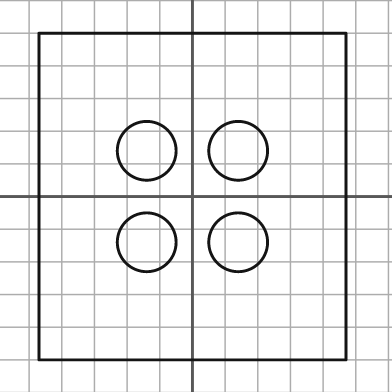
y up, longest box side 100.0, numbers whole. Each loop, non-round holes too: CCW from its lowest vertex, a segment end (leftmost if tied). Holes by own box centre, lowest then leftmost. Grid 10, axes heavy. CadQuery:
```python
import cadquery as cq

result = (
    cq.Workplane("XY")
    .moveTo(-47.0, -50.0)
    .lineTo(47.0, -50.0)
    .lineTo(47.0, 50.0)
    .lineTo(-47.0, 50.0)
    .close()
    .moveTo(-14.0, -14.0)
    .circle(9.0)
    .moveTo(14.0, -14.0)
    .circle(9.0)
    .moveTo(-14.0, 14.0)
    .circle(9.0)
    .moveTo(14.0, 14.0)
    .circle(9.0)
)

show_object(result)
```